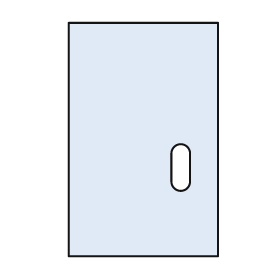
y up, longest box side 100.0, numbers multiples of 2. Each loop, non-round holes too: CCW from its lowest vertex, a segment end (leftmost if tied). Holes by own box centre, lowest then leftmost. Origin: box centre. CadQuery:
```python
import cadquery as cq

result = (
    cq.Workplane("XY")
    .moveTo(-32.0, -50.0)
    .lineTo(32.0, -50.0)
    .lineTo(32.0, 50.0)
    .lineTo(-32.0, 50.0)
    .close()
    .moveTo(12.0, -18.0)
    .threePointArc((16.0, -22.0), (20.0, -18.0))
    .lineTo(20.0, -6.0)
    .threePointArc((16.0, -2.0), (12.0, -6.0))
    .close()
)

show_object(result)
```